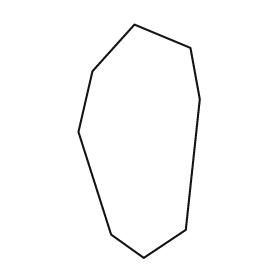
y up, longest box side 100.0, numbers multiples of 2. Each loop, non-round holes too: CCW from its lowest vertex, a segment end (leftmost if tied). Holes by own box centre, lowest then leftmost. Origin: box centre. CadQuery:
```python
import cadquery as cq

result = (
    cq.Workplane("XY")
    .moveTo(2.0, -50.0)
    .lineTo(20.0, -38.0)
    .lineTo(26.0, 18.0)
    .lineTo(22.0, 40.0)
    .lineTo(-2.0, 50.0)
    .lineTo(-20.0, 30.0)
    .lineTo(-26.0, 4.0)
    .lineTo(-12.0, -40.0)
    .close()
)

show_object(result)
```